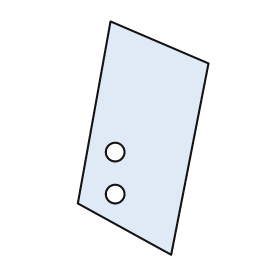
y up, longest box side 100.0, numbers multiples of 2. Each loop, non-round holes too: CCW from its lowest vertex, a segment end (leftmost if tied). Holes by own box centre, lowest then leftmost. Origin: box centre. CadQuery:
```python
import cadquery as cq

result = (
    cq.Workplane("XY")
    .moveTo(12.0, -50.0)
    .lineTo(28.0, 32.0)
    .lineTo(-14.0, 50.0)
    .lineTo(-28.0, -28.0)
    .close()
    .moveTo(-12.0, -24.0)
    .circle(4.0)
    .moveTo(-12.0, -6.0)
    .circle(4.0)
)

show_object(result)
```